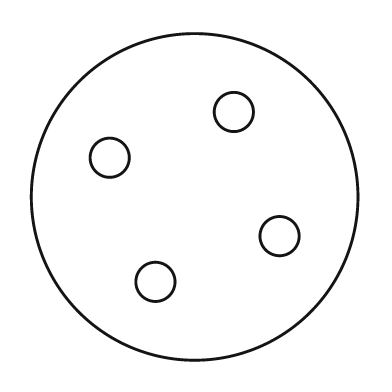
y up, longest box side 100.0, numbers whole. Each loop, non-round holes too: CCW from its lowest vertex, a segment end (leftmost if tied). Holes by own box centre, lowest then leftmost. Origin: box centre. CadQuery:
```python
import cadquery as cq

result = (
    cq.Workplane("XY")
    .moveTo(0.0, 0.0)
    .circle(50.0)
    .moveTo(-12.0, -26.0)
    .circle(6.0)
    .moveTo(26.0, -12.0)
    .circle(6.0)
    .moveTo(-26.0, 12.0)
    .circle(6.0)
    .moveTo(12.0, 26.0)
    .circle(6.0)
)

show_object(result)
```